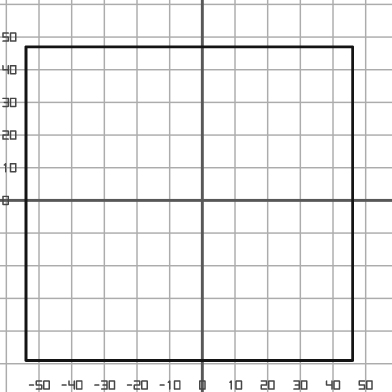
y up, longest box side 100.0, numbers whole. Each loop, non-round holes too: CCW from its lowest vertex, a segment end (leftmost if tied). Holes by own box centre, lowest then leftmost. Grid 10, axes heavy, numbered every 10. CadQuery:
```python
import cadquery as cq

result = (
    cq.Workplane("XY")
    .moveTo(-54.0, -49.0)
    .lineTo(46.0, -49.0)
    .lineTo(46.0, 47.0)
    .lineTo(-54.0, 47.0)
    .close()
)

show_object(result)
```